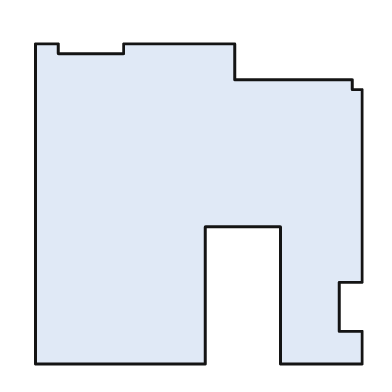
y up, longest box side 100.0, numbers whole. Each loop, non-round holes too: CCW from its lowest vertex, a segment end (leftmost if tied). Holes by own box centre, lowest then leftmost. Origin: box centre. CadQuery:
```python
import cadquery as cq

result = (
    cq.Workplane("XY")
    .moveTo(-50.0, -49.0)
    .lineTo(2.0, -49.0)
    .lineTo(2.0, -7.0)
    .lineTo(25.0, -7.0)
    .lineTo(25.0, -49.0)
    .lineTo(50.0, -49.0)
    .lineTo(50.0, -39.0)
    .lineTo(43.0, -39.0)
    .lineTo(43.0, -24.0)
    .lineTo(50.0, -24.0)
    .lineTo(50.0, 35.0)
    .lineTo(47.0, 35.0)
    .lineTo(47.0, 38.0)
    .lineTo(11.0, 38.0)
    .lineTo(11.0, 49.0)
    .lineTo(-23.0, 49.0)
    .lineTo(-23.0, 46.0)
    .lineTo(-43.0, 46.0)
    .lineTo(-43.0, 49.0)
    .lineTo(-50.0, 49.0)
    .close()
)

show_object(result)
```